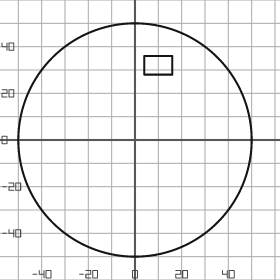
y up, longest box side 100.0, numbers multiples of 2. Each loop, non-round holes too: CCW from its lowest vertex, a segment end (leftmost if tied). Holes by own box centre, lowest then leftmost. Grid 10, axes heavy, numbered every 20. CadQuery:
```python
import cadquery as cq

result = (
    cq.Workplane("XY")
    .moveTo(0.0, 0.0)
    .circle(50.0)
    .moveTo(4.0, 28.0)
    .lineTo(16.0, 28.0)
    .lineTo(16.0, 36.0)
    .lineTo(4.0, 36.0)
    .close()
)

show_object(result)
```